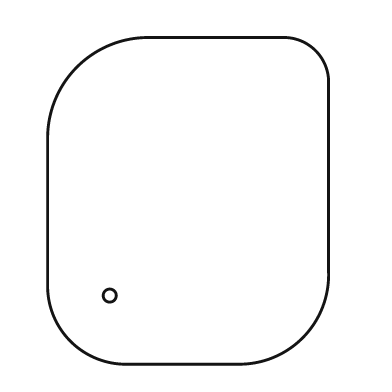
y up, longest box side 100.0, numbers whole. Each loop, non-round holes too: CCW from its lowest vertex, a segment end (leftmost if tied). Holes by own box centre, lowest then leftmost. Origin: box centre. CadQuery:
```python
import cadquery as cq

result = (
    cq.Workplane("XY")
    .moveTo(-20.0, -50.0)
    .lineTo(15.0, -50.0)
    .threePointArc((35.0, -42.0), (43.0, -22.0))
    .lineTo(43.0, 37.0)
    .threePointArc((39.0, 46.0), (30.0, 50.0))
    .lineTo(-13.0, 50.0)
    .threePointArc((-34.0, 41.0), (-43.0, 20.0))
    .lineTo(-43.0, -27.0)
    .threePointArc((-36.0, -43.0), (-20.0, -50.0))
    .close()
    .moveTo(-24.0, -29.0)
    .circle(2.0)
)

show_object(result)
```